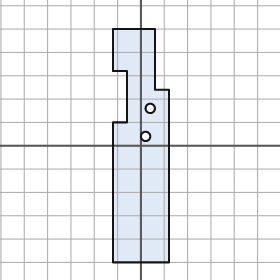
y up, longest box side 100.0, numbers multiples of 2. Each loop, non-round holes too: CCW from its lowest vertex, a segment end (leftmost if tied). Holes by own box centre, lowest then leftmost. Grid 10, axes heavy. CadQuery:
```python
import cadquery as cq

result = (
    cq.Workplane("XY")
    .moveTo(-12.0, -50.0)
    .lineTo(12.0, -50.0)
    .lineTo(12.0, 24.0)
    .lineTo(6.0, 24.0)
    .lineTo(6.0, 50.0)
    .lineTo(-12.0, 50.0)
    .lineTo(-12.0, 32.0)
    .lineTo(-6.0, 32.0)
    .lineTo(-6.0, 10.0)
    .lineTo(-12.0, 10.0)
    .close()
    .moveTo(2.0, 4.0)
    .circle(2.0)
    .moveTo(4.0, 16.0)
    .circle(2.0)
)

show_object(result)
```